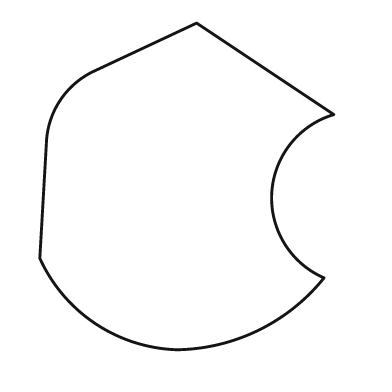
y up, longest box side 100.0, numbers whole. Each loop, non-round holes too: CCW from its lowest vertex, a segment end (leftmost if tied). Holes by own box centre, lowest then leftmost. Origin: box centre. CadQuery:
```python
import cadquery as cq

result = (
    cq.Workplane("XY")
    .moveTo(-3.0, -50.0)
    .threePointArc((22.0, -44.0), (42.0, -28.0))
    .threePointArc((26.0, -2.0), (45.0, 22.0))
    .lineTo(3.0, 50.0)
    .lineTo(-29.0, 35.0)
    .threePointArc((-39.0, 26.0), (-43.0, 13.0))
    .lineTo(-45.0, -22.0)
    .threePointArc((-28.0, -42.0), (-3.0, -50.0))
    .close()
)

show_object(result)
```